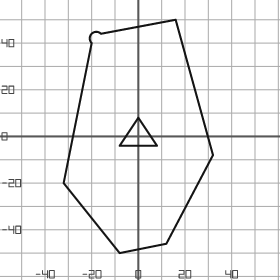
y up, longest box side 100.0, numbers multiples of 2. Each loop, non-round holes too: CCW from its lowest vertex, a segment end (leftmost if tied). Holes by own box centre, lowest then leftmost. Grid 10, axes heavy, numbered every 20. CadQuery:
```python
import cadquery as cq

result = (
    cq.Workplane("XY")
    .moveTo(-8.0, -50.0)
    .lineTo(12.0, -46.0)
    .lineTo(32.0, -8.0)
    .lineTo(16.0, 50.0)
    .lineTo(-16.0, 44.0)
    .threePointArc((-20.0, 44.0), (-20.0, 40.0))
    .lineTo(-32.0, -20.0)
    .close()
    .moveTo(-8.0, -4.0)
    .lineTo(8.0, -4.0)
    .lineTo(0.0, 8.0)
    .close()
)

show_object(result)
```